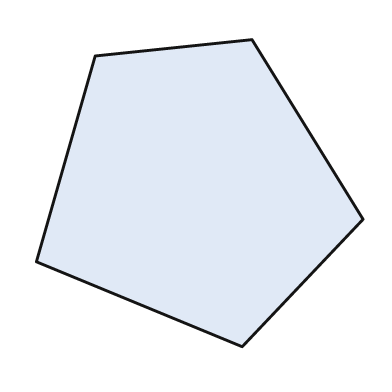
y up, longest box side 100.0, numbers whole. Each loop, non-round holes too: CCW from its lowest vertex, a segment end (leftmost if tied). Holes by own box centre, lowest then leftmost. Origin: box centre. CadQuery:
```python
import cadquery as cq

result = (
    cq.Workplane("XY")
    .moveTo(13.0, -47.0)
    .lineTo(50.0, -8.0)
    .lineTo(16.0, 47.0)
    .lineTo(-32.0, 42.0)
    .lineTo(-50.0, -21.0)
    .close()
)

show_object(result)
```